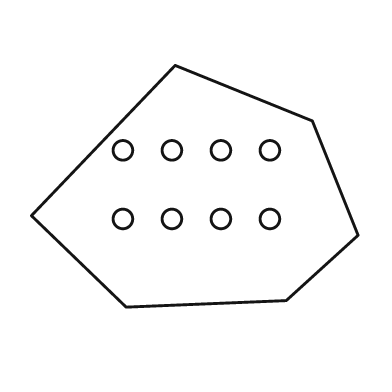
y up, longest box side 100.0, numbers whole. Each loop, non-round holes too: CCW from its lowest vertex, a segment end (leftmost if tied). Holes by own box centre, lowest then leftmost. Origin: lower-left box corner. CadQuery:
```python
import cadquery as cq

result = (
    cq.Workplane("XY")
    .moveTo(29.0, 0.0)
    .lineTo(78.0, 2.0)
    .lineTo(100.0, 22.0)
    .lineTo(86.0, 57.0)
    .lineTo(44.0, 74.0)
    .lineTo(0.0, 28.0)
    .close()
    .moveTo(28.0, 27.0)
    .circle(3.0)
    .moveTo(43.0, 27.0)
    .circle(3.0)
    .moveTo(58.0, 27.0)
    .circle(3.0)
    .moveTo(73.0, 27.0)
    .circle(3.0)
    .moveTo(28.0, 48.0)
    .circle(3.0)
    .moveTo(43.0, 48.0)
    .circle(3.0)
    .moveTo(58.0, 48.0)
    .circle(3.0)
    .moveTo(73.0, 48.0)
    .circle(3.0)
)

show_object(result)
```